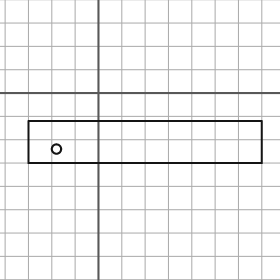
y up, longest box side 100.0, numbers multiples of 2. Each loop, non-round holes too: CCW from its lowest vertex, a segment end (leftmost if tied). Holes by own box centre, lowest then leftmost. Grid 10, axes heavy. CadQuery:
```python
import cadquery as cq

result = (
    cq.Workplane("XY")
    .moveTo(-30.0, -30.0)
    .lineTo(70.0, -30.0)
    .lineTo(70.0, -12.0)
    .lineTo(-30.0, -12.0)
    .close()
    .moveTo(-18.0, -24.0)
    .circle(2.0)
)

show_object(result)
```